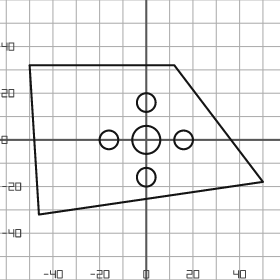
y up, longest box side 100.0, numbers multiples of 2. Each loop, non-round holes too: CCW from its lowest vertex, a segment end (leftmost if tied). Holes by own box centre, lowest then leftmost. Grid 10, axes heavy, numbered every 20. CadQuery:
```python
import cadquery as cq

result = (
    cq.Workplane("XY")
    .moveTo(-46.0, -32.0)
    .lineTo(50.0, -18.0)
    .lineTo(12.0, 32.0)
    .lineTo(-50.0, 32.0)
    .close()
    .moveTo(0.0, -16.0)
    .circle(4.0)
    .moveTo(-16.0, 0.0)
    .circle(4.0)
    .moveTo(0.0, 0.0)
    .circle(6.0)
    .moveTo(16.0, 0.0)
    .circle(4.0)
    .moveTo(0.0, 16.0)
    .circle(4.0)
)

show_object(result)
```